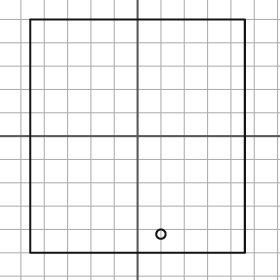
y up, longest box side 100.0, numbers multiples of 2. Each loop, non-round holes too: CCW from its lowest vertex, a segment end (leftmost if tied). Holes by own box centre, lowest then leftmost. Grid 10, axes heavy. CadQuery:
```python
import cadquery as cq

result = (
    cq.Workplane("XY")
    .moveTo(-46.0, -50.0)
    .lineTo(46.0, -50.0)
    .lineTo(46.0, 50.0)
    .lineTo(-46.0, 50.0)
    .close()
    .moveTo(10.0, -42.0)
    .circle(2.0)
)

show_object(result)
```